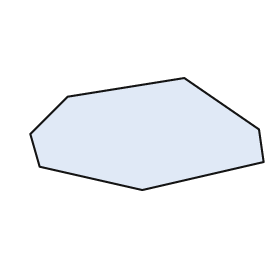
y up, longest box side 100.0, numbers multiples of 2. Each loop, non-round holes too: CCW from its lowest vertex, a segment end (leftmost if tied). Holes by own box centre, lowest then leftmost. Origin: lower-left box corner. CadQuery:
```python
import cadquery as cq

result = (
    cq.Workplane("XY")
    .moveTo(48.0, 0.0)
    .lineTo(100.0, 12.0)
    .lineTo(98.0, 26.0)
    .lineTo(66.0, 48.0)
    .lineTo(16.0, 40.0)
    .lineTo(0.0, 24.0)
    .lineTo(4.0, 10.0)
    .close()
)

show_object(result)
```